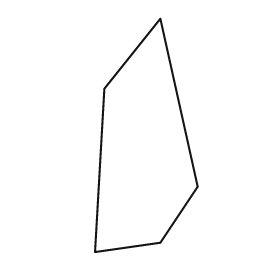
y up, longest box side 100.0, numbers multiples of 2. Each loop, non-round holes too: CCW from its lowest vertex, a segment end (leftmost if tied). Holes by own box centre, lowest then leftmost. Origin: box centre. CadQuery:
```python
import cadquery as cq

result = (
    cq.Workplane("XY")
    .moveTo(-22.0, -50.0)
    .lineTo(6.0, -46.0)
    .lineTo(22.0, -22.0)
    .lineTo(6.0, 50.0)
    .lineTo(-18.0, 20.0)
    .close()
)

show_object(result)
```